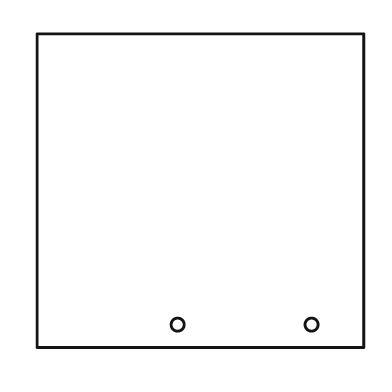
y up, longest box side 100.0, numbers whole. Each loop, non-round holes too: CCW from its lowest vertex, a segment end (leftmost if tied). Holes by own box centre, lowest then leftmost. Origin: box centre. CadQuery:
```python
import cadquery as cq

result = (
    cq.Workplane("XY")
    .moveTo(-50.0, -48.0)
    .lineTo(50.0, -48.0)
    .lineTo(50.0, 48.0)
    .lineTo(-50.0, 48.0)
    .close()
    .moveTo(-7.0, -41.0)
    .circle(2.0)
    .moveTo(34.0, -41.0)
    .circle(2.0)
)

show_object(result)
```